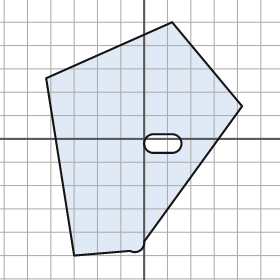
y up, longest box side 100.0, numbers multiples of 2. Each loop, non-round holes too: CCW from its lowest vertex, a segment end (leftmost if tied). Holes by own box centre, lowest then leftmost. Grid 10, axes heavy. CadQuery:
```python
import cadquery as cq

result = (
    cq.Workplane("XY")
    .moveTo(-30.0, -50.0)
    .lineTo(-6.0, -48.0)
    .threePointArc((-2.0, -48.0), (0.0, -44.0))
    .lineTo(42.0, 14.0)
    .lineTo(12.0, 50.0)
    .lineTo(-42.0, 26.0)
    .close()
    .moveTo(4.0, -6.0)
    .lineTo(12.0, -6.0)
    .threePointArc((16.0, -2.0), (12.0, 2.0))
    .lineTo(4.0, 2.0)
    .threePointArc((0.0, -2.0), (4.0, -6.0))
    .close()
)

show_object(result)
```